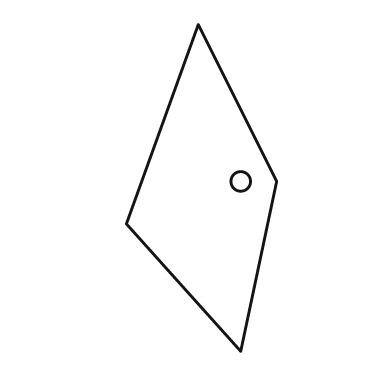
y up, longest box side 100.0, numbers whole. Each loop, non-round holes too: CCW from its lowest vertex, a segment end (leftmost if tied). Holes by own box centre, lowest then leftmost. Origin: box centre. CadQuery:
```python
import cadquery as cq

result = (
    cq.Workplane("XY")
    .moveTo(12.0, -50.0)
    .lineTo(23.0, 2.0)
    .lineTo(-1.0, 50.0)
    .lineTo(-23.0, -11.0)
    .close()
    .moveTo(12.0, 2.0)
    .circle(3.0)
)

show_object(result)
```